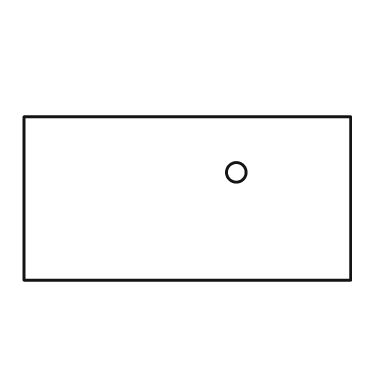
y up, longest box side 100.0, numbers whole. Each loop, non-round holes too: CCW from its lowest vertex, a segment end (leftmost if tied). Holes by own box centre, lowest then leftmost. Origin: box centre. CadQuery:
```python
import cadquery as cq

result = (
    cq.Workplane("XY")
    .moveTo(-50.0, -25.0)
    .lineTo(50.0, -25.0)
    .lineTo(50.0, 25.0)
    .lineTo(-50.0, 25.0)
    .close()
    .moveTo(15.0, 8.0)
    .circle(3.0)
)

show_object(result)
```